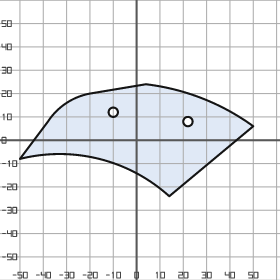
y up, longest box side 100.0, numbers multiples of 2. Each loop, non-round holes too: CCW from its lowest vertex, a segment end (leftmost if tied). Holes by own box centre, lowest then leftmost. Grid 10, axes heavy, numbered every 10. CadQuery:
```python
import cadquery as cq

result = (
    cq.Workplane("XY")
    .moveTo(14.0, -24.0)
    .lineTo(50.0, 6.0)
    .threePointArc((28.0, 18.0), (4.0, 24.0))
    .lineTo(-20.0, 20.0)
    .threePointArc((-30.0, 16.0), (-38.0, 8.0))
    .lineTo(-50.0, -8.0)
    .threePointArc((-16.0, -8.0), (14.0, -24.0))
    .close()
    .moveTo(22.0, 8.0)
    .circle(2.0)
    .moveTo(-10.0, 12.0)
    .circle(2.0)
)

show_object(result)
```